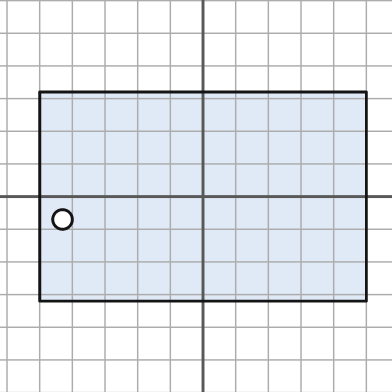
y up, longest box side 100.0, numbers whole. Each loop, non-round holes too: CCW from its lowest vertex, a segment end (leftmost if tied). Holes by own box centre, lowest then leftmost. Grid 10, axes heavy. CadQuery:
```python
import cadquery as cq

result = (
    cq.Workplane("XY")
    .moveTo(-50.0, -32.0)
    .lineTo(50.0, -32.0)
    .lineTo(50.0, 32.0)
    .lineTo(-50.0, 32.0)
    .close()
    .moveTo(-43.0, -7.0)
    .circle(3.0)
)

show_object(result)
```